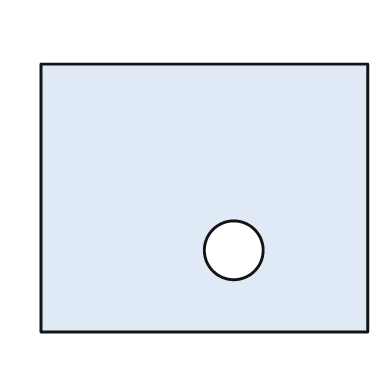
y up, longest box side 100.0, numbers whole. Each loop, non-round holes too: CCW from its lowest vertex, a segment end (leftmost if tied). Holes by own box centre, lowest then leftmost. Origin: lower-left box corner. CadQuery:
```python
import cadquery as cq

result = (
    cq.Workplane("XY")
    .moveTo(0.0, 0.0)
    .lineTo(100.0, 0.0)
    .lineTo(100.0, 82.0)
    .lineTo(0.0, 82.0)
    .close()
    .moveTo(59.0, 25.0)
    .circle(9.0)
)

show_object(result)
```